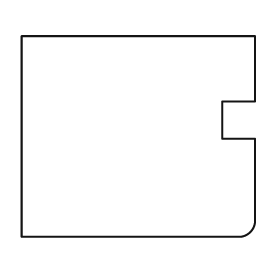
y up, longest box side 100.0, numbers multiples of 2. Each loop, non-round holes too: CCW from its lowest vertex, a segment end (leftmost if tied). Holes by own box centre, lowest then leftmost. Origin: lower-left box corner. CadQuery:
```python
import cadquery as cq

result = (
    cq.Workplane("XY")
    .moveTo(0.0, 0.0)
    .lineTo(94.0, 0.0)
    .threePointArc((98.0, 2.0), (100.0, 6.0))
    .lineTo(100.0, 42.0)
    .lineTo(86.0, 42.0)
    .lineTo(86.0, 58.0)
    .lineTo(100.0, 58.0)
    .lineTo(100.0, 86.0)
    .lineTo(0.0, 86.0)
    .close()
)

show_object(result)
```